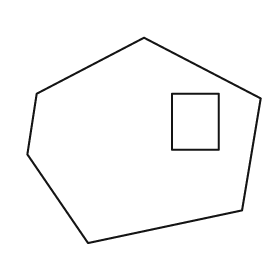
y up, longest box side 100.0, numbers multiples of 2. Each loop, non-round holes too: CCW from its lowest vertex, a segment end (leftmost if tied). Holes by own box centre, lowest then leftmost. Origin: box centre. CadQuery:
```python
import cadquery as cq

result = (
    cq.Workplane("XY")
    .moveTo(-24.0, -44.0)
    .lineTo(42.0, -30.0)
    .lineTo(50.0, 18.0)
    .lineTo(0.0, 44.0)
    .lineTo(-46.0, 20.0)
    .lineTo(-50.0, -6.0)
    .close()
    .moveTo(12.0, -4.0)
    .lineTo(32.0, -4.0)
    .lineTo(32.0, 20.0)
    .lineTo(12.0, 20.0)
    .close()
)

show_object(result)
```